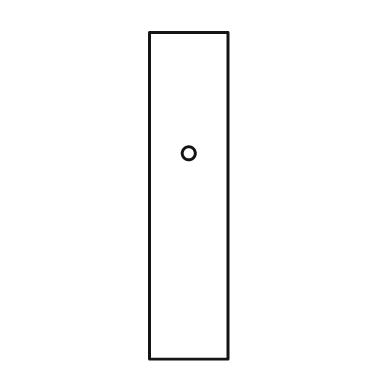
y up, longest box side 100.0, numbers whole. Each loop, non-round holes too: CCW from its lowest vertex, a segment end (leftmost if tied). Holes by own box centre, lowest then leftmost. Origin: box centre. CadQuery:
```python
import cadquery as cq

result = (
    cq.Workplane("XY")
    .moveTo(-12.0, -50.0)
    .lineTo(12.0, -50.0)
    .lineTo(12.0, 50.0)
    .lineTo(-12.0, 50.0)
    .close()
    .moveTo(0.0, 13.0)
    .circle(2.0)
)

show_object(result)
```